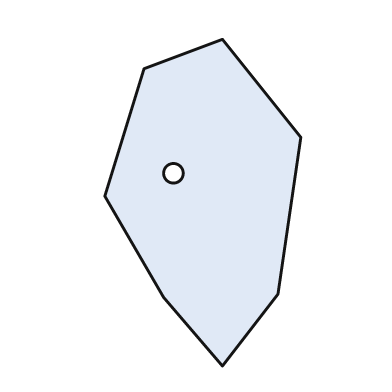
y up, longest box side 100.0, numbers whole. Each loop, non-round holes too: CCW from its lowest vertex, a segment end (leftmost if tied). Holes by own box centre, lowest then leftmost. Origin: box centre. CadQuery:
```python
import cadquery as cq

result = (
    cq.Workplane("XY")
    .moveTo(6.0, -50.0)
    .lineTo(23.0, -28.0)
    .lineTo(30.0, 20.0)
    .lineTo(6.0, 50.0)
    .lineTo(-18.0, 41.0)
    .lineTo(-30.0, 2.0)
    .lineTo(-12.0, -29.0)
    .close()
    .moveTo(-9.0, 9.0)
    .circle(3.0)
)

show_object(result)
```